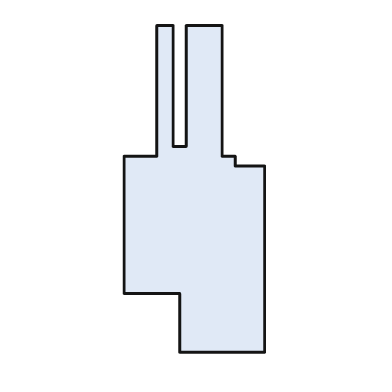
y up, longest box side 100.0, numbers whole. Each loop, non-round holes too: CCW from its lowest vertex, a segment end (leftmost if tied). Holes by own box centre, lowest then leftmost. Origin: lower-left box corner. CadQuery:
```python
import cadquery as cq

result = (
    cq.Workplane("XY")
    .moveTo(17.0, 0.0)
    .lineTo(43.0, 0.0)
    .lineTo(43.0, 57.0)
    .lineTo(34.0, 57.0)
    .lineTo(34.0, 60.0)
    .lineTo(30.0, 60.0)
    .lineTo(30.0, 100.0)
    .lineTo(19.0, 100.0)
    .lineTo(19.0, 63.0)
    .lineTo(15.0, 63.0)
    .lineTo(15.0, 100.0)
    .lineTo(10.0, 100.0)
    .lineTo(10.0, 60.0)
    .lineTo(0.0, 60.0)
    .lineTo(0.0, 18.0)
    .lineTo(17.0, 18.0)
    .close()
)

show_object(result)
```